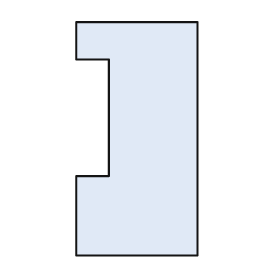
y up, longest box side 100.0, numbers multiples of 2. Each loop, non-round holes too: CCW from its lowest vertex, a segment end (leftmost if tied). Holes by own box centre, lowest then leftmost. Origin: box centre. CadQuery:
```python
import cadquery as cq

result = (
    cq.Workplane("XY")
    .moveTo(-26.0, -50.0)
    .lineTo(26.0, -50.0)
    .lineTo(26.0, 50.0)
    .lineTo(-26.0, 50.0)
    .lineTo(-26.0, 34.0)
    .lineTo(-12.0, 34.0)
    .lineTo(-12.0, -16.0)
    .lineTo(-26.0, -16.0)
    .close()
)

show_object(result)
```